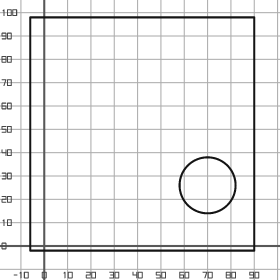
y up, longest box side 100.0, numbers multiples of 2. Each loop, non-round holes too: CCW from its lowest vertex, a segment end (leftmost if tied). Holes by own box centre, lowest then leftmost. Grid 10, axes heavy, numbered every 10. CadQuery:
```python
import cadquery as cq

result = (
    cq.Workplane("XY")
    .moveTo(-6.0, -2.0)
    .lineTo(90.0, -2.0)
    .lineTo(90.0, 98.0)
    .lineTo(-6.0, 98.0)
    .close()
    .moveTo(70.0, 26.0)
    .circle(12.0)
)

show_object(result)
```